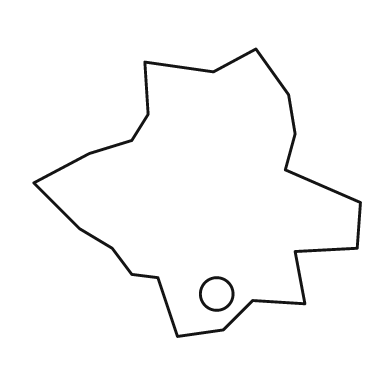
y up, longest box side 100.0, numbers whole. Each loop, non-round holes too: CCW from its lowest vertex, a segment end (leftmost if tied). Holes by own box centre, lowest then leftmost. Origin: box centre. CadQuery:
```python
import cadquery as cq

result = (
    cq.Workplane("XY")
    .moveTo(-6.0, -44.0)
    .lineTo(8.0, -42.0)
    .lineTo(17.0, -33.0)
    .lineTo(33.0, -34.0)
    .lineTo(30.0, -18.0)
    .lineTo(49.0, -17.0)
    .lineTo(50.0, -3.0)
    .lineTo(27.0, 7.0)
    .lineTo(30.0, 18.0)
    .lineTo(28.0, 30.0)
    .lineTo(18.0, 44.0)
    .lineTo(5.0, 37.0)
    .lineTo(-16.0, 40.0)
    .lineTo(-15.0, 24.0)
    .lineTo(-20.0, 16.0)
    .lineTo(-33.0, 12.0)
    .lineTo(-50.0, 3.0)
    .lineTo(-36.0, -11.0)
    .lineTo(-26.0, -17.0)
    .lineTo(-20.0, -25.0)
    .lineTo(-12.0, -26.0)
    .close()
    .moveTo(6.0, -31.0)
    .circle(5.0)
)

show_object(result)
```